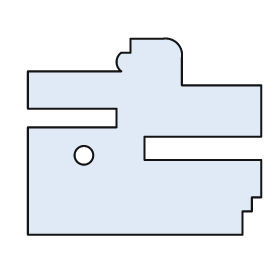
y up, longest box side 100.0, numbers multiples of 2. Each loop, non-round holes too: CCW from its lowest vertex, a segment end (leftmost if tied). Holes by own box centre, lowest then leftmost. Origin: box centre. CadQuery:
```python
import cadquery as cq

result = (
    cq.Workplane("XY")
    .moveTo(-50.0, -42.0)
    .lineTo(42.0, -42.0)
    .lineTo(42.0, -32.0)
    .lineTo(46.0, -32.0)
    .lineTo(46.0, -26.0)
    .lineTo(50.0, -26.0)
    .lineTo(50.0, -10.0)
    .lineTo(0.0, -10.0)
    .lineTo(0.0, 0.0)
    .lineTo(50.0, 0.0)
    .lineTo(50.0, 22.0)
    .lineTo(16.0, 22.0)
    .lineTo(16.0, 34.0)
    .threePointArc((14.0, 40.0), (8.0, 42.0))
    .lineTo(-6.0, 42.0)
    .lineTo(-6.0, 36.0)
    .lineTo(-10.0, 36.0)
    .threePointArc((-12.0, 32.0), (-10.0, 28.0))
    .lineTo(-50.0, 28.0)
    .lineTo(-50.0, 12.0)
    .lineTo(-12.0, 12.0)
    .lineTo(-12.0, 4.0)
    .lineTo(-50.0, 4.0)
    .close()
    .moveTo(-26.0, -8.0)
    .circle(4.0)
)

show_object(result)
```